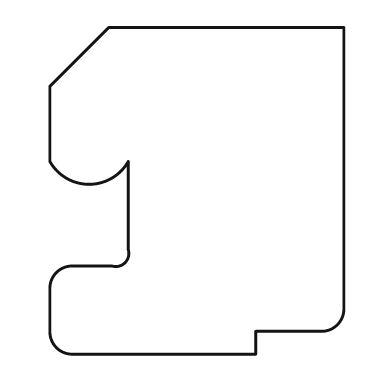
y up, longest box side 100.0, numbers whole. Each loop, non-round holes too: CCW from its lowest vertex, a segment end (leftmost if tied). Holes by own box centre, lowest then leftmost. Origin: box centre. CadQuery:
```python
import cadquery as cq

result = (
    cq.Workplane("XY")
    .moveTo(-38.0, -50.0)
    .lineTo(18.0, -50.0)
    .lineTo(18.0, -43.0)
    .lineTo(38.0, -43.0)
    .threePointArc((43.0, -41.0), (45.0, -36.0))
    .lineTo(45.0, 50.0)
    .lineTo(-27.0, 50.0)
    .lineTo(-45.0, 32.0)
    .lineTo(-45.0, 9.0)
    .threePointArc((-33.0, 2.0), (-21.0, 9.0))
    .lineTo(-21.0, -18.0)
    .threePointArc((-22.0, -22.0), (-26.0, -23.0))
    .lineTo(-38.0, -23.0)
    .threePointArc((-43.0, -25.0), (-45.0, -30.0))
    .lineTo(-45.0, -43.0)
    .threePointArc((-43.0, -48.0), (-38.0, -50.0))
    .close()
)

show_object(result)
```